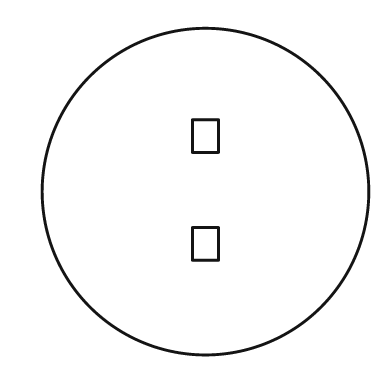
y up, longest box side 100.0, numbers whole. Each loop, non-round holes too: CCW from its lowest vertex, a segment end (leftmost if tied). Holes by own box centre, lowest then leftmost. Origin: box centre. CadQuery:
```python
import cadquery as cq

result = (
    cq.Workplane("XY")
    .moveTo(0.0, 0.0)
    .circle(50.0)
    .moveTo(-4.0, -21.0)
    .lineTo(4.0, -21.0)
    .lineTo(4.0, -11.0)
    .lineTo(-4.0, -11.0)
    .close()
    .moveTo(-4.0, 12.0)
    .lineTo(4.0, 12.0)
    .lineTo(4.0, 22.0)
    .lineTo(-4.0, 22.0)
    .close()
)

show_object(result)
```